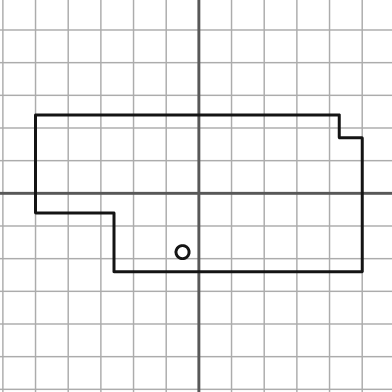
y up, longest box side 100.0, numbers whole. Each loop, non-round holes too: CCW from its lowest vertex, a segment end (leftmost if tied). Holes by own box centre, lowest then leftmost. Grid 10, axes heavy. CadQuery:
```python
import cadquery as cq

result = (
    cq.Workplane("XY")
    .moveTo(-26.0, -24.0)
    .lineTo(50.0, -24.0)
    .lineTo(50.0, 17.0)
    .lineTo(43.0, 17.0)
    .lineTo(43.0, 24.0)
    .lineTo(-50.0, 24.0)
    .lineTo(-50.0, -6.0)
    .lineTo(-26.0, -6.0)
    .close()
    .moveTo(-5.0, -18.0)
    .circle(2.0)
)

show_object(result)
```